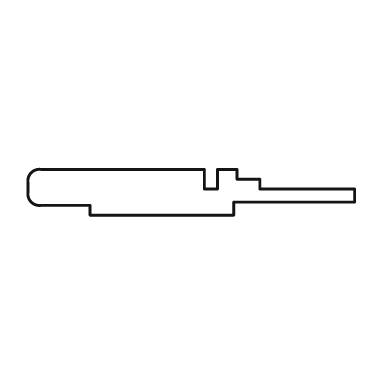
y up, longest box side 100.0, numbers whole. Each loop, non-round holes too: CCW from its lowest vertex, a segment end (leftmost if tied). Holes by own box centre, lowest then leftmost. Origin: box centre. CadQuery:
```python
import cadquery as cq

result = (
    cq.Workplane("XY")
    .moveTo(-31.0, -7.0)
    .lineTo(13.0, -7.0)
    .lineTo(13.0, -3.0)
    .lineTo(50.0, -3.0)
    .lineTo(50.0, 1.0)
    .lineTo(21.0, 1.0)
    .lineTo(21.0, 4.0)
    .lineTo(14.0, 4.0)
    .lineTo(14.0, 7.0)
    .lineTo(8.0, 7.0)
    .lineTo(8.0, 1.0)
    .lineTo(4.0, 1.0)
    .lineTo(4.0, 7.0)
    .lineTo(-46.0, 7.0)
    .threePointArc((-49.0, 6.0), (-50.0, 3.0))
    .lineTo(-50.0, 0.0)
    .threePointArc((-49.0, -3.0), (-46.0, -4.0))
    .lineTo(-31.0, -4.0)
    .close()
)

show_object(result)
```